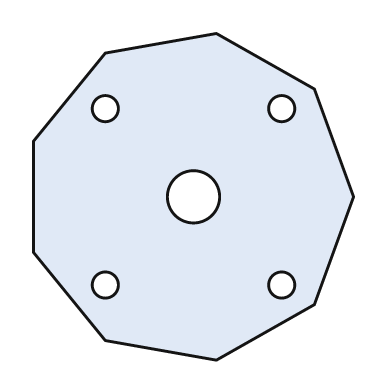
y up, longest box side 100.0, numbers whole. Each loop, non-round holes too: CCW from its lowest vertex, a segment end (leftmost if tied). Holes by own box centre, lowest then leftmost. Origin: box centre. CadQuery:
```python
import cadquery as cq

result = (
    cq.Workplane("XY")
    .moveTo(7.0, -50.0)
    .lineTo(37.0, -33.0)
    .lineTo(49.0, 0.0)
    .lineTo(37.0, 33.0)
    .lineTo(7.0, 50.0)
    .lineTo(-27.0, 44.0)
    .lineTo(-49.0, 17.0)
    .lineTo(-49.0, -17.0)
    .lineTo(-27.0, -44.0)
    .close()
    .moveTo(-27.0, -27.0)
    .circle(4.0)
    .moveTo(27.0, -27.0)
    .circle(4.0)
    .moveTo(0.0, 0.0)
    .circle(8.0)
    .moveTo(-27.0, 27.0)
    .circle(4.0)
    .moveTo(27.0, 27.0)
    .circle(4.0)
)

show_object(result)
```